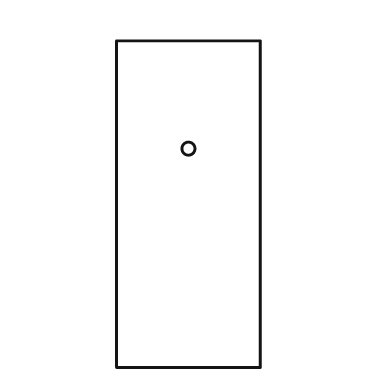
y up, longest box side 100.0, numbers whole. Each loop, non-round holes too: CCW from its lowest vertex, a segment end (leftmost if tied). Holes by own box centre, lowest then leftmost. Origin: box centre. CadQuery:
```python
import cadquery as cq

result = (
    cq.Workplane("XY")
    .moveTo(-22.0, -50.0)
    .lineTo(22.0, -50.0)
    .lineTo(22.0, 50.0)
    .lineTo(-22.0, 50.0)
    .close()
    .moveTo(0.0, 17.0)
    .circle(2.0)
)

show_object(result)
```